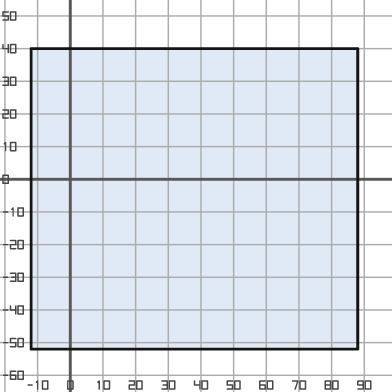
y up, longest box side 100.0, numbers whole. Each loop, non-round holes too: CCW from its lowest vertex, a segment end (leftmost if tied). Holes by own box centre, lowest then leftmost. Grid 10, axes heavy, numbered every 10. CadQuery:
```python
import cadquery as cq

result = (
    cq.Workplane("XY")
    .moveTo(-12.0, -52.0)
    .lineTo(88.0, -52.0)
    .lineTo(88.0, 40.0)
    .lineTo(-12.0, 40.0)
    .close()
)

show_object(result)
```